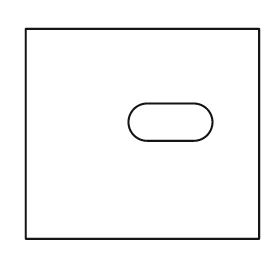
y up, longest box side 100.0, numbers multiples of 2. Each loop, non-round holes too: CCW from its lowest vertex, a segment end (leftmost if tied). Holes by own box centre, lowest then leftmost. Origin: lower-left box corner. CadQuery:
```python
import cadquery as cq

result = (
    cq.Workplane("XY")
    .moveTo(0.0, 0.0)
    .lineTo(100.0, 0.0)
    .lineTo(100.0, 90.0)
    .lineTo(0.0, 90.0)
    .close()
    .moveTo(52.0, 42.0)
    .lineTo(72.0, 42.0)
    .threePointArc((80.0, 50.0), (72.0, 58.0))
    .lineTo(52.0, 58.0)
    .threePointArc((44.0, 50.0), (52.0, 42.0))
    .close()
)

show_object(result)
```